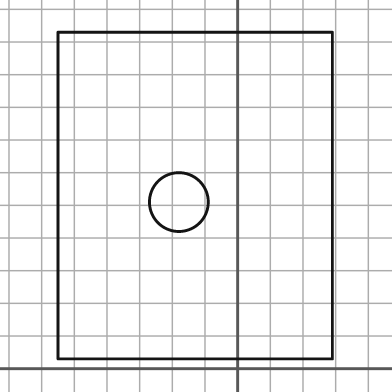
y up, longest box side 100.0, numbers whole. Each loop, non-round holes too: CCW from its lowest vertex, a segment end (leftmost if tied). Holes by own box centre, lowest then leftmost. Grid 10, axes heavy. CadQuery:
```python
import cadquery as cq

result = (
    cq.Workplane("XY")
    .moveTo(-55.0, 3.0)
    .lineTo(29.0, 3.0)
    .lineTo(29.0, 103.0)
    .lineTo(-55.0, 103.0)
    .close()
    .moveTo(-18.0, 51.0)
    .circle(9.0)
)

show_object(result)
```